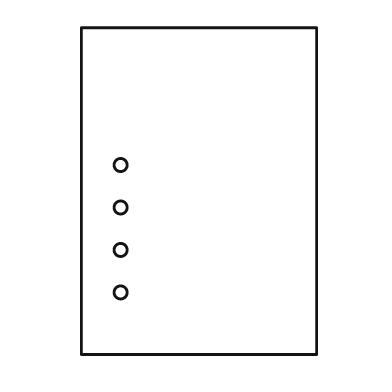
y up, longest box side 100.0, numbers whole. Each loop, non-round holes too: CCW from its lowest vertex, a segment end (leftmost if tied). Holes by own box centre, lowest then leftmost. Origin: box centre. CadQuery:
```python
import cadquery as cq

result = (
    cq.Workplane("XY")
    .moveTo(-36.0, -50.0)
    .lineTo(36.0, -50.0)
    .lineTo(36.0, 50.0)
    .lineTo(-36.0, 50.0)
    .close()
    .moveTo(-24.0, -31.0)
    .circle(2.0)
    .moveTo(-24.0, -18.0)
    .circle(2.0)
    .moveTo(-24.0, -5.0)
    .circle(2.0)
    .moveTo(-24.0, 8.0)
    .circle(2.0)
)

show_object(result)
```